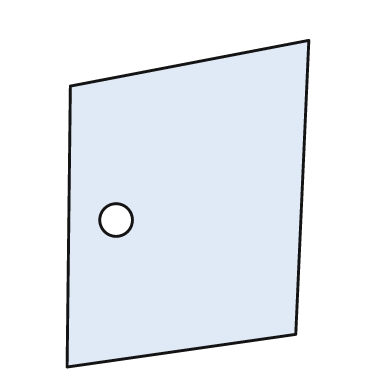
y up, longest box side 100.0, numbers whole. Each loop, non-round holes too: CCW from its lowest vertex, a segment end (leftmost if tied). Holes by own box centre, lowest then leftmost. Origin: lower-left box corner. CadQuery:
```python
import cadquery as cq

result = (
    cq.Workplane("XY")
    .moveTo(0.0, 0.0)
    .lineTo(70.0, 10.0)
    .lineTo(74.0, 100.0)
    .lineTo(1.0, 86.0)
    .close()
    .moveTo(15.0, 45.0)
    .circle(5.0)
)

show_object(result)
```